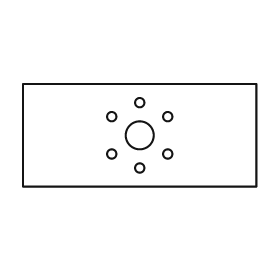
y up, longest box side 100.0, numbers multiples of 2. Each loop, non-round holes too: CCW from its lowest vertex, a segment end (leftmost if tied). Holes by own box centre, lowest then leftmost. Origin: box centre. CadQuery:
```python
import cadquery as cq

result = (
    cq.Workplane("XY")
    .moveTo(-50.0, -22.0)
    .lineTo(50.0, -22.0)
    .lineTo(50.0, 22.0)
    .lineTo(-50.0, 22.0)
    .close()
    .moveTo(0.0, -14.0)
    .circle(2.0)
    .moveTo(-12.0, -8.0)
    .circle(2.0)
    .moveTo(12.0, -8.0)
    .circle(2.0)
    .moveTo(0.0, 0.0)
    .circle(6.0)
    .moveTo(-12.0, 8.0)
    .circle(2.0)
    .moveTo(12.0, 8.0)
    .circle(2.0)
    .moveTo(0.0, 14.0)
    .circle(2.0)
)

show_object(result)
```